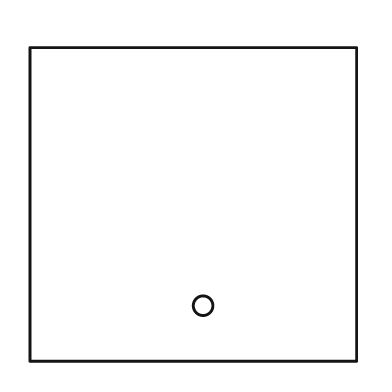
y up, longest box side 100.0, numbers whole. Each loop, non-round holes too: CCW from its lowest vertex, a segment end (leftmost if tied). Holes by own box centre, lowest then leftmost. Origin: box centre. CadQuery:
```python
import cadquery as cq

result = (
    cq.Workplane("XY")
    .moveTo(-50.0, -48.0)
    .lineTo(50.0, -48.0)
    .lineTo(50.0, 48.0)
    .lineTo(-50.0, 48.0)
    .close()
    .moveTo(3.0, -31.0)
    .circle(3.0)
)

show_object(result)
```